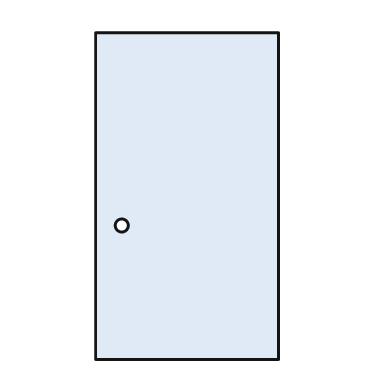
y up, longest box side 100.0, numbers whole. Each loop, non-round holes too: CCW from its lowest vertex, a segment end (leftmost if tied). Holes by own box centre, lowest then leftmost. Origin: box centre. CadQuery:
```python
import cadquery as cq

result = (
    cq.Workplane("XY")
    .moveTo(-28.0, -50.0)
    .lineTo(28.0, -50.0)
    .lineTo(28.0, 50.0)
    .lineTo(-28.0, 50.0)
    .close()
    .moveTo(-20.0, -9.0)
    .circle(2.0)
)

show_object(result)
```